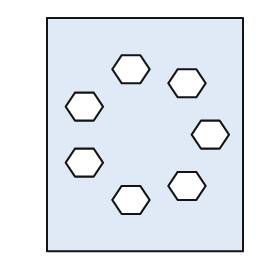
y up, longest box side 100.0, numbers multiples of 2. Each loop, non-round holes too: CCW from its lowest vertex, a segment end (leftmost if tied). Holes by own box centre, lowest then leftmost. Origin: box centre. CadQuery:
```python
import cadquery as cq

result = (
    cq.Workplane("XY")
    .moveTo(-42.0, -50.0)
    .lineTo(42.0, -50.0)
    .lineTo(42.0, 50.0)
    .lineTo(-42.0, 50.0)
    .close()
    .moveTo(-10.0, -34.0)
    .lineTo(-2.0, -34.0)
    .lineTo(2.0, -28.0)
    .lineTo(-2.0, -22.0)
    .lineTo(-10.0, -22.0)
    .lineTo(-14.0, -28.0)
    .close()
    .moveTo(14.0, -28.0)
    .lineTo(22.0, -28.0)
    .lineTo(26.0, -22.0)
    .lineTo(22.0, -16.0)
    .lineTo(14.0, -16.0)
    .lineTo(10.0, -22.0)
    .close()
    .moveTo(-30.0, -18.0)
    .lineTo(-22.0, -18.0)
    .lineTo(-18.0, -12.0)
    .lineTo(-22.0, -6.0)
    .lineTo(-30.0, -6.0)
    .lineTo(-34.0, -12.0)
    .close()
    .moveTo(24.0, -6.0)
    .lineTo(32.0, -6.0)
    .lineTo(36.0, 0.0)
    .lineTo(32.0, 6.0)
    .lineTo(24.0, 6.0)
    .lineTo(20.0, 0.0)
    .close()
    .moveTo(-30.0, 6.0)
    .lineTo(-22.0, 6.0)
    .lineTo(-18.0, 12.0)
    .lineTo(-22.0, 18.0)
    .lineTo(-30.0, 18.0)
    .lineTo(-34.0, 12.0)
    .close()
    .moveTo(14.0, 16.0)
    .lineTo(22.0, 16.0)
    .lineTo(26.0, 22.0)
    .lineTo(22.0, 28.0)
    .lineTo(14.0, 28.0)
    .lineTo(10.0, 22.0)
    .close()
    .moveTo(-10.0, 22.0)
    .lineTo(-2.0, 22.0)
    .lineTo(2.0, 28.0)
    .lineTo(-2.0, 34.0)
    .lineTo(-10.0, 34.0)
    .lineTo(-14.0, 28.0)
    .close()
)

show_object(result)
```